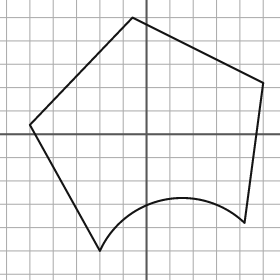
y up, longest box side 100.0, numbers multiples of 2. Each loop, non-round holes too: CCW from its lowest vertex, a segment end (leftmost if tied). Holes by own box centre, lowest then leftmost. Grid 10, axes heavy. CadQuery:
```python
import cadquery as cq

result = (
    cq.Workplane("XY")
    .moveTo(-20.0, -50.0)
    .threePointArc((8.0, -28.0), (42.0, -38.0))
    .lineTo(50.0, 22.0)
    .lineTo(-6.0, 50.0)
    .lineTo(-50.0, 4.0)
    .close()
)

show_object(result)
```